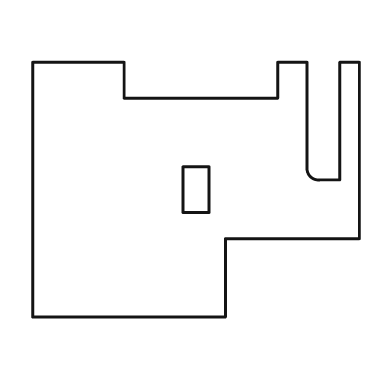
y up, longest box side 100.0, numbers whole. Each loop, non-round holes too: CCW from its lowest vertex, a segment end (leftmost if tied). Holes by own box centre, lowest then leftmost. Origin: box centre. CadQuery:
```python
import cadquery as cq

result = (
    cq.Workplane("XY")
    .moveTo(-50.0, -39.0)
    .lineTo(9.0, -39.0)
    .lineTo(9.0, -15.0)
    .lineTo(50.0, -15.0)
    .lineTo(50.0, 39.0)
    .lineTo(44.0, 39.0)
    .lineTo(44.0, 3.0)
    .lineTo(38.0, 3.0)
    .threePointArc((35.0, 4.0), (34.0, 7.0))
    .lineTo(34.0, 39.0)
    .lineTo(25.0, 39.0)
    .lineTo(25.0, 28.0)
    .lineTo(-22.0, 28.0)
    .lineTo(-22.0, 39.0)
    .lineTo(-50.0, 39.0)
    .close()
    .moveTo(-4.0, -7.0)
    .lineTo(4.0, -7.0)
    .lineTo(4.0, 7.0)
    .lineTo(-4.0, 7.0)
    .close()
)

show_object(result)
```